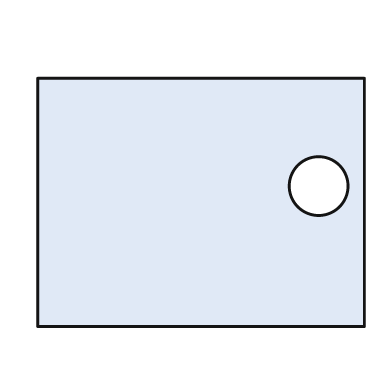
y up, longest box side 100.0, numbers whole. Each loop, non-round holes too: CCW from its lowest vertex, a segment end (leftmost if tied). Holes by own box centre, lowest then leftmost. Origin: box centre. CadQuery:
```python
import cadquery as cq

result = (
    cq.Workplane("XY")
    .moveTo(-50.0, -38.0)
    .lineTo(50.0, -38.0)
    .lineTo(50.0, 38.0)
    .lineTo(-50.0, 38.0)
    .close()
    .moveTo(36.0, 5.0)
    .circle(9.0)
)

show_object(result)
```